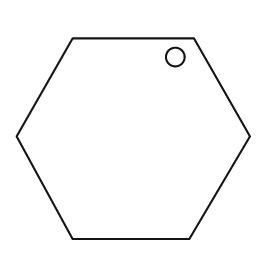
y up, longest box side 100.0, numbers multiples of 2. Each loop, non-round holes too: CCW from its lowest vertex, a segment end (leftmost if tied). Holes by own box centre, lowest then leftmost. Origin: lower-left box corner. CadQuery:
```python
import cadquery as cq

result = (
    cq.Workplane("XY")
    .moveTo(24.0, 0.0)
    .lineTo(74.0, 0.0)
    .lineTo(100.0, 44.0)
    .lineTo(76.0, 86.0)
    .lineTo(24.0, 86.0)
    .lineTo(0.0, 44.0)
    .close()
    .moveTo(68.0, 78.0)
    .circle(4.0)
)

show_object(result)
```